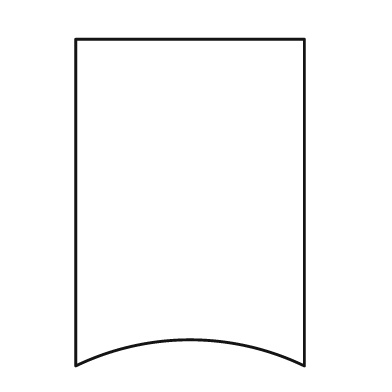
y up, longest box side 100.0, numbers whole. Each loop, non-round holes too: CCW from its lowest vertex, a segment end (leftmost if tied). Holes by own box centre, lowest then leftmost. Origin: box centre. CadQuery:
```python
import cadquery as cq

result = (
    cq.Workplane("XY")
    .moveTo(-35.0, -50.0)
    .threePointArc((0.0, -42.0), (35.0, -50.0))
    .lineTo(35.0, 50.0)
    .lineTo(-35.0, 50.0)
    .close()
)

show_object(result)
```